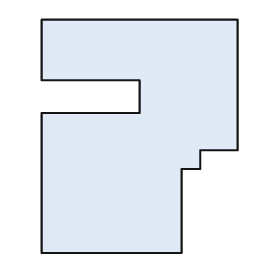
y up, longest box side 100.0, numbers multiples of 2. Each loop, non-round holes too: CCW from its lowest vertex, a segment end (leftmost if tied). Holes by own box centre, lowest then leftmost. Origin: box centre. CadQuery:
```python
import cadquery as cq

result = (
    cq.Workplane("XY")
    .moveTo(-42.0, -50.0)
    .lineTo(18.0, -50.0)
    .lineTo(18.0, -14.0)
    .lineTo(26.0, -14.0)
    .lineTo(26.0, -6.0)
    .lineTo(42.0, -6.0)
    .lineTo(42.0, 50.0)
    .lineTo(-42.0, 50.0)
    .lineTo(-42.0, 24.0)
    .lineTo(0.0, 24.0)
    .lineTo(0.0, 10.0)
    .lineTo(-42.0, 10.0)
    .close()
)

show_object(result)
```